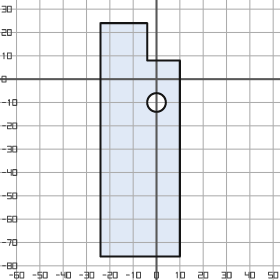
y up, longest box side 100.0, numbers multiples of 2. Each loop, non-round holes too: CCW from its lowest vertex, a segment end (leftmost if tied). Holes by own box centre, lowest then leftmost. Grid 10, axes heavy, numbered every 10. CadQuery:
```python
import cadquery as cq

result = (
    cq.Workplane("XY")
    .moveTo(-24.0, -76.0)
    .lineTo(10.0, -76.0)
    .lineTo(10.0, 8.0)
    .lineTo(-4.0, 8.0)
    .lineTo(-4.0, 24.0)
    .lineTo(-24.0, 24.0)
    .close()
    .moveTo(0.0, -10.0)
    .circle(4.0)
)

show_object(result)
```